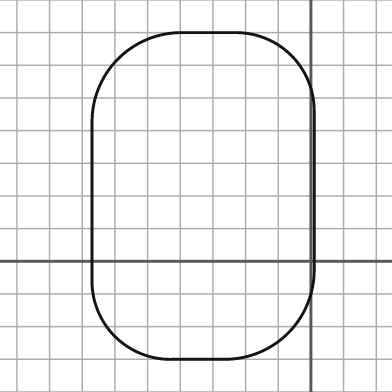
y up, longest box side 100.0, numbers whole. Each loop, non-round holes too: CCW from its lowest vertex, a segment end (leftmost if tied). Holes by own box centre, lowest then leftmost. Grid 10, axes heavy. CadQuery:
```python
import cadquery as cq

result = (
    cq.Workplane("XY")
    .moveTo(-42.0, -30.0)
    .lineTo(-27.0, -30.0)
    .threePointArc((-7.0, -22.0), (1.0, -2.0))
    .lineTo(1.0, 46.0)
    .threePointArc((-6.0, 63.0), (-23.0, 70.0))
    .lineTo(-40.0, 70.0)
    .threePointArc((-59.0, 62.0), (-67.0, 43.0))
    .lineTo(-67.0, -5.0)
    .threePointArc((-60.0, -23.0), (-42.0, -30.0))
    .close()
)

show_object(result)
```